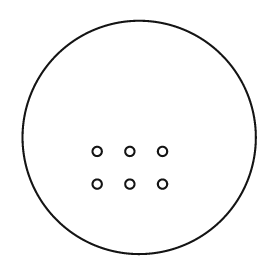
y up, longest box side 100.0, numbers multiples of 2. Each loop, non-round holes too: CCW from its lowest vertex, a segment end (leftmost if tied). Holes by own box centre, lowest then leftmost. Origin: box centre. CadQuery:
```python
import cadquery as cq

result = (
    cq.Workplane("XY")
    .moveTo(0.0, 0.0)
    .circle(50.0)
    .moveTo(-18.0, -20.0)
    .circle(2.0)
    .moveTo(-4.0, -20.0)
    .circle(2.0)
    .moveTo(10.0, -20.0)
    .circle(2.0)
    .moveTo(-18.0, -6.0)
    .circle(2.0)
    .moveTo(-4.0, -6.0)
    .circle(2.0)
    .moveTo(10.0, -6.0)
    .circle(2.0)
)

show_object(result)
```